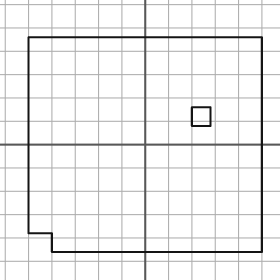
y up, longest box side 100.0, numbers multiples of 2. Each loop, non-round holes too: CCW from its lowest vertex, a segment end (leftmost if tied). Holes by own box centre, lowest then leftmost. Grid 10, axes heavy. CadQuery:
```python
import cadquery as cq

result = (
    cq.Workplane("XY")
    .moveTo(-40.0, -46.0)
    .lineTo(50.0, -46.0)
    .lineTo(50.0, 46.0)
    .lineTo(-50.0, 46.0)
    .lineTo(-50.0, -38.0)
    .lineTo(-40.0, -38.0)
    .close()
    .moveTo(20.0, 8.0)
    .lineTo(28.0, 8.0)
    .lineTo(28.0, 16.0)
    .lineTo(20.0, 16.0)
    .close()
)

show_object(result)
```